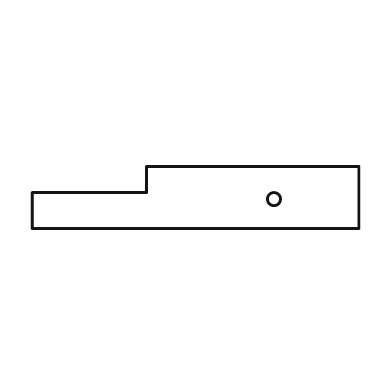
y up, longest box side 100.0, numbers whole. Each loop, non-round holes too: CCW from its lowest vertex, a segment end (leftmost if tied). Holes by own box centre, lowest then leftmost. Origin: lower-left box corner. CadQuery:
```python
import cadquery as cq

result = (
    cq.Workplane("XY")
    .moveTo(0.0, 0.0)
    .lineTo(100.0, 0.0)
    .lineTo(100.0, 19.0)
    .lineTo(35.0, 19.0)
    .lineTo(35.0, 11.0)
    .lineTo(0.0, 11.0)
    .close()
    .moveTo(74.0, 9.0)
    .circle(2.0)
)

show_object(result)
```